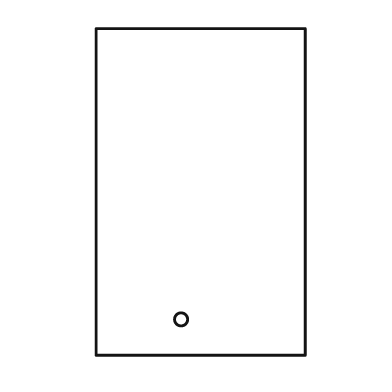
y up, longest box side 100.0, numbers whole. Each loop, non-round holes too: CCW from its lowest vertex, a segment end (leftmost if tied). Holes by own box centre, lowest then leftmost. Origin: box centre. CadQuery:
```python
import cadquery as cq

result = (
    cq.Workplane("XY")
    .moveTo(-32.0, -50.0)
    .lineTo(32.0, -50.0)
    .lineTo(32.0, 50.0)
    .lineTo(-32.0, 50.0)
    .close()
    .moveTo(-6.0, -39.0)
    .circle(2.0)
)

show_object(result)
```